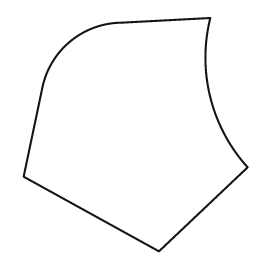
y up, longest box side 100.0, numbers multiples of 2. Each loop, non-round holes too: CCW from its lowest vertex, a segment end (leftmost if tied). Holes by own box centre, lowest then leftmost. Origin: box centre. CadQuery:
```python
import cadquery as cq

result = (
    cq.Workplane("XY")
    .moveTo(10.0, -50.0)
    .lineTo(48.0, -14.0)
    .threePointArc((32.0, 16.0), (32.0, 50.0))
    .lineTo(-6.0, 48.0)
    .threePointArc((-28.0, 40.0), (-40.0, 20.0))
    .lineTo(-48.0, -18.0)
    .close()
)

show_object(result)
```